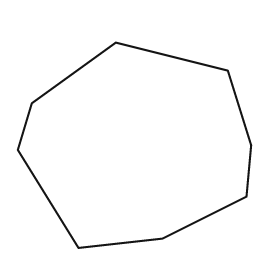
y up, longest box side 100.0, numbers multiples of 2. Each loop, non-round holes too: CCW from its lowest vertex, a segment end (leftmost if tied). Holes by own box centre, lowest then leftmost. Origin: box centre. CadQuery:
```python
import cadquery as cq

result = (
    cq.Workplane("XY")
    .moveTo(-24.0, -44.0)
    .lineTo(12.0, -40.0)
    .lineTo(48.0, -22.0)
    .lineTo(50.0, 0.0)
    .lineTo(40.0, 32.0)
    .lineTo(-8.0, 44.0)
    .lineTo(-44.0, 18.0)
    .lineTo(-50.0, -2.0)
    .close()
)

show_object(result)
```